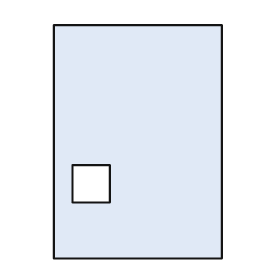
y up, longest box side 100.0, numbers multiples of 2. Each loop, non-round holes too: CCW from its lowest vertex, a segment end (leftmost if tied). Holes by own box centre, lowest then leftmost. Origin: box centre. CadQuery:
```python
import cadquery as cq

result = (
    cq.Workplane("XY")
    .moveTo(-36.0, -50.0)
    .lineTo(36.0, -50.0)
    .lineTo(36.0, 50.0)
    .lineTo(-36.0, 50.0)
    .close()
    .moveTo(-28.0, -26.0)
    .lineTo(-12.0, -26.0)
    .lineTo(-12.0, -10.0)
    .lineTo(-28.0, -10.0)
    .close()
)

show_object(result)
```